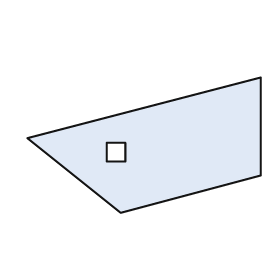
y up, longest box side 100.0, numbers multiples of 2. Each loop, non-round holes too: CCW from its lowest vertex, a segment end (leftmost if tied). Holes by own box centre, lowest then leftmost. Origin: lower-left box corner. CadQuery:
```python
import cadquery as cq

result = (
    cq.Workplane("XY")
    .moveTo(40.0, 0.0)
    .lineTo(100.0, 16.0)
    .lineTo(100.0, 58.0)
    .lineTo(0.0, 32.0)
    .close()
    .moveTo(34.0, 22.0)
    .lineTo(42.0, 22.0)
    .lineTo(42.0, 30.0)
    .lineTo(34.0, 30.0)
    .close()
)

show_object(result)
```